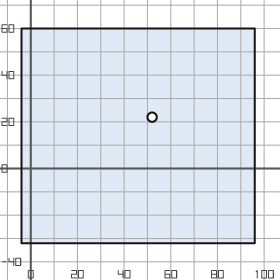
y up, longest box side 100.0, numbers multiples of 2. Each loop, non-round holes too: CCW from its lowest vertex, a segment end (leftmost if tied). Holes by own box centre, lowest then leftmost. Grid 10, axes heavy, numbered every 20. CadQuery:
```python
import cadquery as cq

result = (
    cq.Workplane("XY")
    .moveTo(-4.0, -32.0)
    .lineTo(96.0, -32.0)
    .lineTo(96.0, 60.0)
    .lineTo(-4.0, 60.0)
    .close()
    .moveTo(52.0, 22.0)
    .circle(2.0)
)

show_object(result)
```